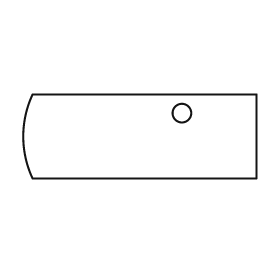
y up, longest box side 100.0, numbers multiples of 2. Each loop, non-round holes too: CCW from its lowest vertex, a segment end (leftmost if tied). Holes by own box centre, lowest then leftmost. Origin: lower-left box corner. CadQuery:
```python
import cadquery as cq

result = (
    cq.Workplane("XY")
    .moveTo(4.0, 0.0)
    .lineTo(100.0, 0.0)
    .lineTo(100.0, 36.0)
    .lineTo(4.0, 36.0)
    .threePointArc((0.0, 18.0), (4.0, 0.0))
    .close()
    .moveTo(68.0, 28.0)
    .circle(4.0)
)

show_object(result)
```